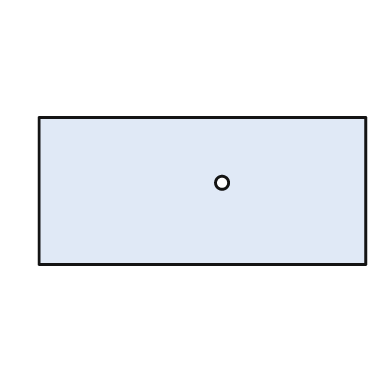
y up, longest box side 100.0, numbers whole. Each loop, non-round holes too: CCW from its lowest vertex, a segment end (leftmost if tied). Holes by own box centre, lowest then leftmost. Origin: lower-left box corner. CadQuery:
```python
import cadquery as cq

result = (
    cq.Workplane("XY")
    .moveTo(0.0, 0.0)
    .lineTo(100.0, 0.0)
    .lineTo(100.0, 45.0)
    .lineTo(0.0, 45.0)
    .close()
    .moveTo(56.0, 25.0)
    .circle(2.0)
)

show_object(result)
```